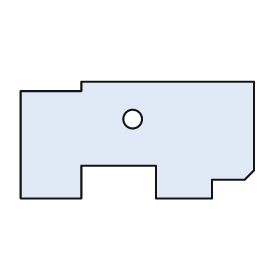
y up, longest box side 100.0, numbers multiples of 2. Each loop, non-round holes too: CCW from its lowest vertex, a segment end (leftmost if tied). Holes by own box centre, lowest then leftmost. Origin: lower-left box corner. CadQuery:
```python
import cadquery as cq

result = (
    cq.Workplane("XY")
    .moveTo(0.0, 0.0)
    .lineTo(26.0, 0.0)
    .lineTo(26.0, 14.0)
    .lineTo(58.0, 14.0)
    .lineTo(58.0, 0.0)
    .lineTo(82.0, 0.0)
    .lineTo(82.0, 8.0)
    .lineTo(96.0, 8.0)
    .lineTo(100.0, 12.0)
    .lineTo(100.0, 50.0)
    .lineTo(26.0, 50.0)
    .lineTo(26.0, 46.0)
    .lineTo(0.0, 46.0)
    .close()
    .moveTo(48.0, 34.0)
    .circle(4.0)
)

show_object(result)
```